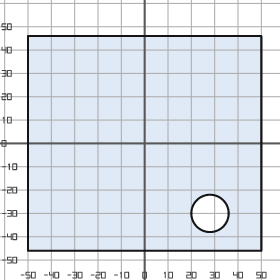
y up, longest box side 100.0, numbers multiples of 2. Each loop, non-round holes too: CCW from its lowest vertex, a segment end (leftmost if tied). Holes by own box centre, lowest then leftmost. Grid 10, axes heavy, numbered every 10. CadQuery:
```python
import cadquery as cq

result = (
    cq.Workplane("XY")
    .moveTo(-50.0, -46.0)
    .lineTo(50.0, -46.0)
    .lineTo(50.0, 46.0)
    .lineTo(-50.0, 46.0)
    .close()
    .moveTo(28.0, -30.0)
    .circle(8.0)
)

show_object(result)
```